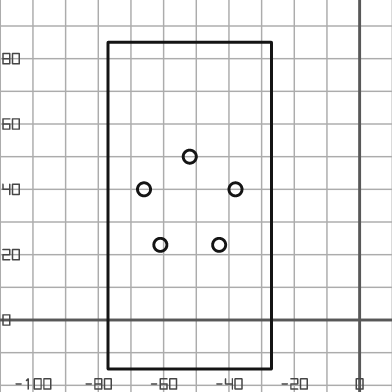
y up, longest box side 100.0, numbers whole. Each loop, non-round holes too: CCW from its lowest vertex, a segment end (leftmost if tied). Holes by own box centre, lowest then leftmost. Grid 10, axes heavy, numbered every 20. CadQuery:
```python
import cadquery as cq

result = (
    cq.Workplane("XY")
    .moveTo(-77.0, -15.0)
    .lineTo(-27.0, -15.0)
    .lineTo(-27.0, 85.0)
    .lineTo(-77.0, 85.0)
    .close()
    .moveTo(-61.0, 23.0)
    .circle(2.0)
    .moveTo(-43.0, 23.0)
    .circle(2.0)
    .moveTo(-66.0, 40.0)
    .circle(2.0)
    .moveTo(-38.0, 40.0)
    .circle(2.0)
    .moveTo(-52.0, 50.0)
    .circle(2.0)
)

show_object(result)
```